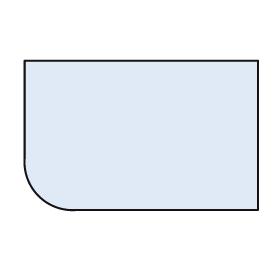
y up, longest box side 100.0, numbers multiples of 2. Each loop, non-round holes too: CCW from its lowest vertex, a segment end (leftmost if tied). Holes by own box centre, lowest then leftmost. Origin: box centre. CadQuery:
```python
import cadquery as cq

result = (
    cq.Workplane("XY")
    .moveTo(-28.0, -32.0)
    .lineTo(50.0, -32.0)
    .lineTo(50.0, 32.0)
    .lineTo(-50.0, 32.0)
    .lineTo(-50.0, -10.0)
    .threePointArc((-44.0, -26.0), (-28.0, -32.0))
    .close()
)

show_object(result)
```